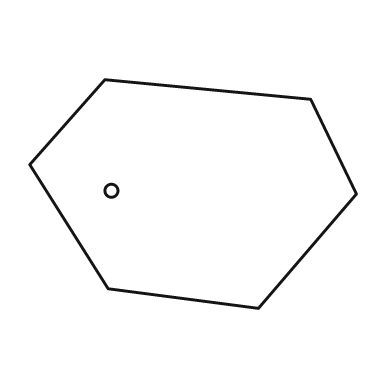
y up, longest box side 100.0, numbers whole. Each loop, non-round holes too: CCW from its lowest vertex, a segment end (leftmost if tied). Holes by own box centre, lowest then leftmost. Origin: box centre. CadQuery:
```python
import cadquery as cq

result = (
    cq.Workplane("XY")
    .moveTo(20.0, -35.0)
    .lineTo(50.0, 0.0)
    .lineTo(36.0, 29.0)
    .lineTo(-27.0, 35.0)
    .lineTo(-50.0, 9.0)
    .lineTo(-26.0, -29.0)
    .close()
    .moveTo(-25.0, 1.0)
    .circle(2.0)
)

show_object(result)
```